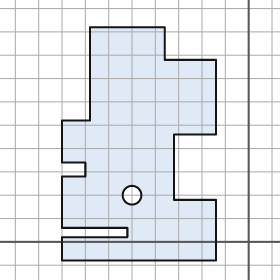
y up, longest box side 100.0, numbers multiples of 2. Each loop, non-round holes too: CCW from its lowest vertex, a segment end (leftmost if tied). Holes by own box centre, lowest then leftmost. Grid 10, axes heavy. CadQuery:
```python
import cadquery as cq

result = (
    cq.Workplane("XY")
    .moveTo(-80.0, -8.0)
    .lineTo(-14.0, -8.0)
    .lineTo(-14.0, 18.0)
    .lineTo(-32.0, 18.0)
    .lineTo(-32.0, 46.0)
    .lineTo(-14.0, 46.0)
    .lineTo(-14.0, 78.0)
    .lineTo(-36.0, 78.0)
    .lineTo(-36.0, 92.0)
    .lineTo(-68.0, 92.0)
    .lineTo(-68.0, 52.0)
    .lineTo(-80.0, 52.0)
    .lineTo(-80.0, 34.0)
    .lineTo(-70.0, 34.0)
    .lineTo(-70.0, 28.0)
    .lineTo(-80.0, 28.0)
    .lineTo(-80.0, 6.0)
    .lineTo(-52.0, 6.0)
    .lineTo(-52.0, 2.0)
    .lineTo(-80.0, 2.0)
    .close()
    .moveTo(-50.0, 20.0)
    .circle(4.0)
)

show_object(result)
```